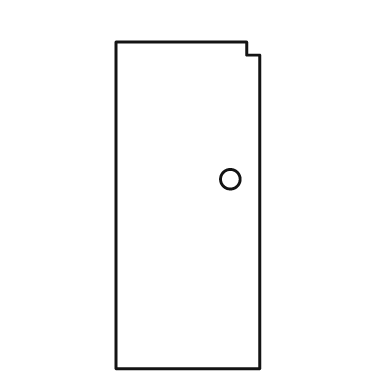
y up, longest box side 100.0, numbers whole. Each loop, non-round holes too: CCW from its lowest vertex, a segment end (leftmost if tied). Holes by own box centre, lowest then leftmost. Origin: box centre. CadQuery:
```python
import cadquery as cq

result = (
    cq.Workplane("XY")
    .moveTo(-22.0, -50.0)
    .lineTo(22.0, -50.0)
    .lineTo(22.0, 46.0)
    .lineTo(18.0, 46.0)
    .lineTo(18.0, 50.0)
    .lineTo(-22.0, 50.0)
    .close()
    .moveTo(13.0, 8.0)
    .circle(3.0)
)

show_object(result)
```